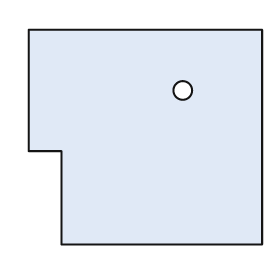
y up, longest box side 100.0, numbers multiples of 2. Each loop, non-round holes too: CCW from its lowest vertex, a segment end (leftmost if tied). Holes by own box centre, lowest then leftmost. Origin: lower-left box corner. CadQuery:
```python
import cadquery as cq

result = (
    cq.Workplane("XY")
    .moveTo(14.0, 0.0)
    .lineTo(100.0, 0.0)
    .lineTo(100.0, 92.0)
    .lineTo(0.0, 92.0)
    .lineTo(0.0, 40.0)
    .lineTo(14.0, 40.0)
    .close()
    .moveTo(66.0, 66.0)
    .circle(4.0)
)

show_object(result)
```